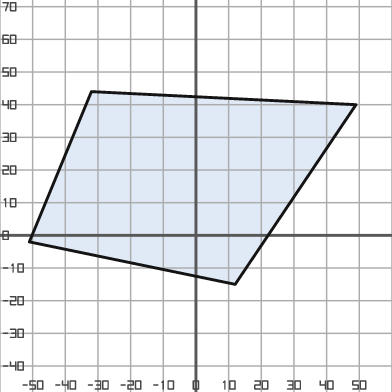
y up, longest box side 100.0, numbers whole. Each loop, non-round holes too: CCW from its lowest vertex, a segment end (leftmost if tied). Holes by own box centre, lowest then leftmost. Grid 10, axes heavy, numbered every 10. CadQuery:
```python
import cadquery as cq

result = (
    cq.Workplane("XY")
    .moveTo(12.0, -15.0)
    .lineTo(49.0, 40.0)
    .lineTo(-32.0, 44.0)
    .lineTo(-51.0, -2.0)
    .close()
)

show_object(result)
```